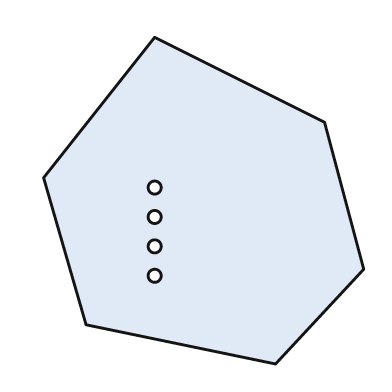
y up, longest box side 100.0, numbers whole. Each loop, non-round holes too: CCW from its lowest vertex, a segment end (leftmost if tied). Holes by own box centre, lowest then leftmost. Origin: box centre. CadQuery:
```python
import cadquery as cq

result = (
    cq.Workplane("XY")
    .moveTo(22.0, -50.0)
    .lineTo(49.0, -21.0)
    .lineTo(37.0, 24.0)
    .lineTo(-15.0, 50.0)
    .lineTo(-49.0, 7.0)
    .lineTo(-36.0, -38.0)
    .close()
    .moveTo(-15.0, -23.0)
    .circle(2.0)
    .moveTo(-15.0, -14.0)
    .circle(2.0)
    .moveTo(-15.0, -5.0)
    .circle(2.0)
    .moveTo(-15.0, 4.0)
    .circle(2.0)
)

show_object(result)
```